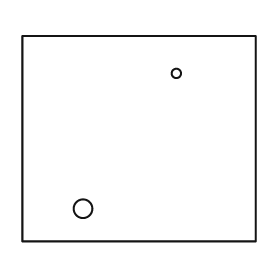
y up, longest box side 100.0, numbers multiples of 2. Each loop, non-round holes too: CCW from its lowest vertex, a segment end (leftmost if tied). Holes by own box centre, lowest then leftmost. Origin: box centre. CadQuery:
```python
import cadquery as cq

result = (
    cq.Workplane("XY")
    .moveTo(-50.0, -44.0)
    .lineTo(50.0, -44.0)
    .lineTo(50.0, 44.0)
    .lineTo(-50.0, 44.0)
    .close()
    .moveTo(-24.0, -30.0)
    .circle(4.0)
    .moveTo(16.0, 28.0)
    .circle(2.0)
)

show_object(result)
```